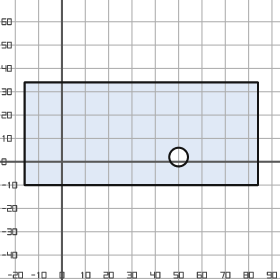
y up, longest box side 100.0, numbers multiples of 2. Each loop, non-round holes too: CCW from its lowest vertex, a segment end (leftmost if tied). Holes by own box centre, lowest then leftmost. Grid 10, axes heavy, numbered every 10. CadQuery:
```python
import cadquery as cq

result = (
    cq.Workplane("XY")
    .moveTo(-16.0, -10.0)
    .lineTo(84.0, -10.0)
    .lineTo(84.0, 34.0)
    .lineTo(-16.0, 34.0)
    .close()
    .moveTo(50.0, 2.0)
    .circle(4.0)
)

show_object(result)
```